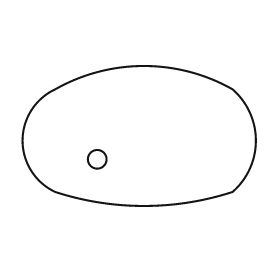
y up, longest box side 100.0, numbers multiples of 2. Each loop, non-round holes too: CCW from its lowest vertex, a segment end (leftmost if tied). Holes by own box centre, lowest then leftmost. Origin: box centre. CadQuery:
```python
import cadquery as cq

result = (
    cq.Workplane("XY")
    .moveTo(-36.0, -24.0)
    .threePointArc((2.0, -30.0), (40.0, -24.0))
    .threePointArc((50.0, -2.0), (40.0, 20.0))
    .threePointArc((2.0, 30.0), (-36.0, 20.0))
    .threePointArc((-50.0, -2.0), (-36.0, -24.0))
    .close()
    .moveTo(-18.0, -10.0)
    .circle(4.0)
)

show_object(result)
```